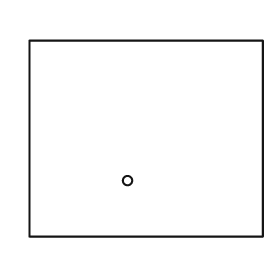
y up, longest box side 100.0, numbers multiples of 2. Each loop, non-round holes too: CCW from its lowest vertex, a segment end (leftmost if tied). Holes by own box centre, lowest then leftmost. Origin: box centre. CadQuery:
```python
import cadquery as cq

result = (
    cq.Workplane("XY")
    .moveTo(-50.0, -42.0)
    .lineTo(50.0, -42.0)
    .lineTo(50.0, 42.0)
    .lineTo(-50.0, 42.0)
    .close()
    .moveTo(-8.0, -18.0)
    .circle(2.0)
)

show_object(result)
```